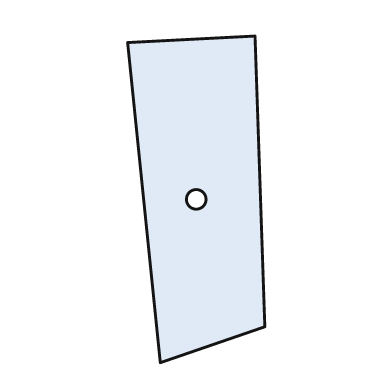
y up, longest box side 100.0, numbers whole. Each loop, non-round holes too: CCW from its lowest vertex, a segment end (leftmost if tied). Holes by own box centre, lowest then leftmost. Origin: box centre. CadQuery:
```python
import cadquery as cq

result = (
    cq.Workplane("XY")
    .moveTo(-11.0, -50.0)
    .lineTo(21.0, -39.0)
    .lineTo(18.0, 50.0)
    .lineTo(-21.0, 48.0)
    .close()
    .moveTo(0.0, 0.0)
    .circle(3.0)
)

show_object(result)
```